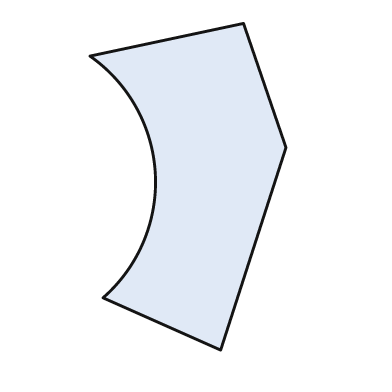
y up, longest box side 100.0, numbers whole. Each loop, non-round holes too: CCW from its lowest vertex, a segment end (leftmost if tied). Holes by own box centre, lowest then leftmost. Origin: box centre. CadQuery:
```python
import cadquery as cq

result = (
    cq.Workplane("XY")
    .moveTo(10.0, -50.0)
    .lineTo(30.0, 12.0)
    .lineTo(17.0, 50.0)
    .lineTo(-30.0, 40.0)
    .threePointArc((-10.0, 4.0), (-26.0, -34.0))
    .close()
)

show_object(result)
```